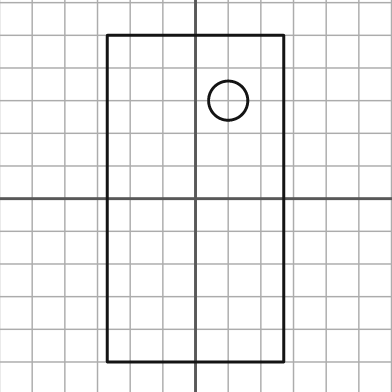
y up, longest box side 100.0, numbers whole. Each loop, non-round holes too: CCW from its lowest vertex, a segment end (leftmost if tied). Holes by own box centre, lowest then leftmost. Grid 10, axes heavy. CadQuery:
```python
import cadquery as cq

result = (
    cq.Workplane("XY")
    .moveTo(-27.0, -50.0)
    .lineTo(27.0, -50.0)
    .lineTo(27.0, 50.0)
    .lineTo(-27.0, 50.0)
    .close()
    .moveTo(10.0, 30.0)
    .circle(6.0)
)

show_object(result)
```